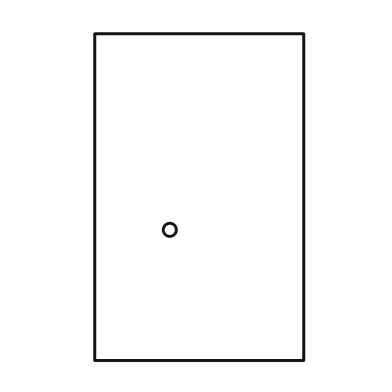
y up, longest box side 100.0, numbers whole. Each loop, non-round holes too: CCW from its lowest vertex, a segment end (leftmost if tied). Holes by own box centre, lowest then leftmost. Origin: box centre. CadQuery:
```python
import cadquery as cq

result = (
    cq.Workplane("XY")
    .moveTo(-32.0, -50.0)
    .lineTo(32.0, -50.0)
    .lineTo(32.0, 50.0)
    .lineTo(-32.0, 50.0)
    .close()
    .moveTo(-9.0, -10.0)
    .circle(2.0)
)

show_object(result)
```